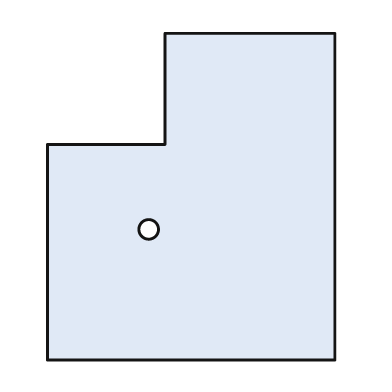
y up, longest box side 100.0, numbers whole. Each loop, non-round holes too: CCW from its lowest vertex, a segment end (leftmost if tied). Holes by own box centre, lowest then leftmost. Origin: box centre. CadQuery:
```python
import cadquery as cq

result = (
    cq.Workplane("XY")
    .moveTo(-44.0, -50.0)
    .lineTo(44.0, -50.0)
    .lineTo(44.0, 50.0)
    .lineTo(-8.0, 50.0)
    .lineTo(-8.0, 16.0)
    .lineTo(-44.0, 16.0)
    .close()
    .moveTo(-13.0, -10.0)
    .circle(3.0)
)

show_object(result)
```